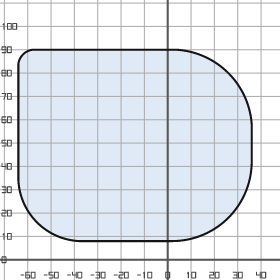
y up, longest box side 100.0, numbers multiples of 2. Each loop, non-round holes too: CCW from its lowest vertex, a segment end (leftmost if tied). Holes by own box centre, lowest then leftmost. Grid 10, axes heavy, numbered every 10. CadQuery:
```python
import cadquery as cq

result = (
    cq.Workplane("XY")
    .moveTo(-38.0, 8.0)
    .lineTo(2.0, 8.0)
    .threePointArc((26.0, 18.0), (36.0, 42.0))
    .lineTo(36.0, 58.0)
    .threePointArc((26.0, 80.0), (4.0, 90.0))
    .lineTo(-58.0, 90.0)
    .threePointArc((-62.0, 88.0), (-64.0, 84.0))
    .lineTo(-64.0, 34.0)
    .threePointArc((-56.0, 16.0), (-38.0, 8.0))
    .close()
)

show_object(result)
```